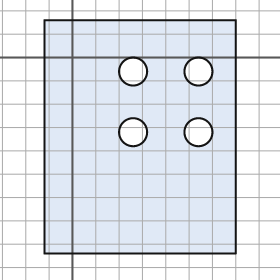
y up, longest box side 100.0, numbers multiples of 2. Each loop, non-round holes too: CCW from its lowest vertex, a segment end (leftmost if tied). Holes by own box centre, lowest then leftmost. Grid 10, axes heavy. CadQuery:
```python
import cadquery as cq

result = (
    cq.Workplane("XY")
    .moveTo(-12.0, -84.0)
    .lineTo(70.0, -84.0)
    .lineTo(70.0, 16.0)
    .lineTo(-12.0, 16.0)
    .close()
    .moveTo(26.0, -32.0)
    .circle(6.0)
    .moveTo(54.0, -32.0)
    .circle(6.0)
    .moveTo(26.0, -6.0)
    .circle(6.0)
    .moveTo(54.0, -6.0)
    .circle(6.0)
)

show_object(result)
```